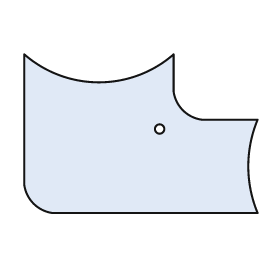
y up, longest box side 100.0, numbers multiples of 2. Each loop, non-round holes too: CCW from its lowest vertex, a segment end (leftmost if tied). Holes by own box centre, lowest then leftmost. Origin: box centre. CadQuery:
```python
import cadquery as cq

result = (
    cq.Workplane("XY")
    .moveTo(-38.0, -34.0)
    .lineTo(50.0, -34.0)
    .threePointArc((46.0, -14.0), (50.0, 6.0))
    .lineTo(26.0, 6.0)
    .threePointArc((18.0, 10.0), (14.0, 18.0))
    .lineTo(14.0, 34.0)
    .threePointArc((-18.0, 22.0), (-50.0, 34.0))
    .lineTo(-50.0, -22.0)
    .threePointArc((-46.0, -30.0), (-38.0, -34.0))
    .close()
    .moveTo(8.0, 2.0)
    .circle(2.0)
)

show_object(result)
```